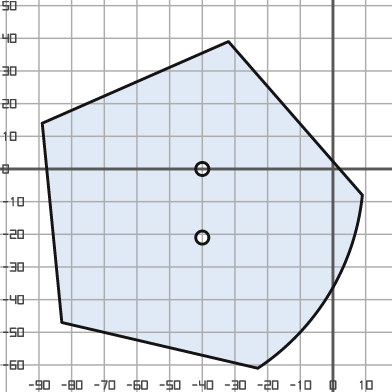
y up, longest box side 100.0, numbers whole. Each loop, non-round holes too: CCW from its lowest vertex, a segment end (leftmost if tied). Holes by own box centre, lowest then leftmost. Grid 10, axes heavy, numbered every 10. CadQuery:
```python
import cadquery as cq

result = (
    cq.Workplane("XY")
    .moveTo(-23.0, -61.0)
    .threePointArc((-1.0, -38.0), (9.0, -8.0))
    .lineTo(-32.0, 39.0)
    .lineTo(-89.0, 14.0)
    .lineTo(-83.0, -47.0)
    .close()
    .moveTo(-40.0, -21.0)
    .circle(2.0)
    .moveTo(-40.0, 0.0)
    .circle(2.0)
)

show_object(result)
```